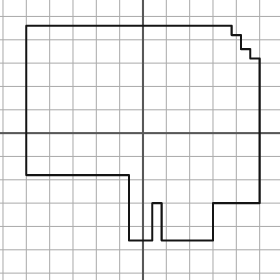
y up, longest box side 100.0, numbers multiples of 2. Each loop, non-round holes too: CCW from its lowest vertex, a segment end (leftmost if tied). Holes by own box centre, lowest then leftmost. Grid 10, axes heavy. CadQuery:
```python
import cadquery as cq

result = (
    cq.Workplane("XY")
    .moveTo(-6.0, -46.0)
    .lineTo(4.0, -46.0)
    .lineTo(4.0, -30.0)
    .lineTo(8.0, -30.0)
    .lineTo(8.0, -46.0)
    .lineTo(30.0, -46.0)
    .lineTo(30.0, -30.0)
    .lineTo(50.0, -30.0)
    .lineTo(50.0, 32.0)
    .lineTo(46.0, 32.0)
    .lineTo(46.0, 36.0)
    .lineTo(42.0, 36.0)
    .lineTo(42.0, 42.0)
    .lineTo(38.0, 42.0)
    .lineTo(38.0, 46.0)
    .lineTo(-50.0, 46.0)
    .lineTo(-50.0, -18.0)
    .lineTo(-6.0, -18.0)
    .close()
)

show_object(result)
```